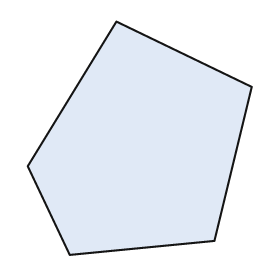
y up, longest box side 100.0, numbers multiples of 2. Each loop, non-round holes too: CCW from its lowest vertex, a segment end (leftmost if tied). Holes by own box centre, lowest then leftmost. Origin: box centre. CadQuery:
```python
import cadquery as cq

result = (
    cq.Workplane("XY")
    .moveTo(-30.0, -50.0)
    .lineTo(32.0, -44.0)
    .lineTo(48.0, 22.0)
    .lineTo(-10.0, 50.0)
    .lineTo(-48.0, -12.0)
    .close()
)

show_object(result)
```